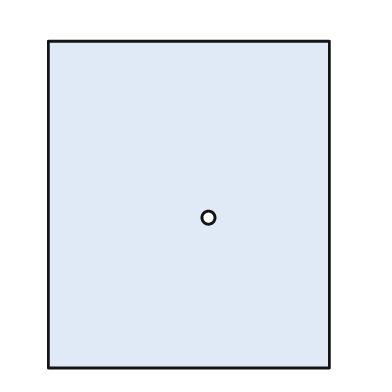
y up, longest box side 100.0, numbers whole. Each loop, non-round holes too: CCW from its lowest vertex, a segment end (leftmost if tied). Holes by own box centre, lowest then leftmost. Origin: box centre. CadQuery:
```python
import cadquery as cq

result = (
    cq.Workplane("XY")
    .moveTo(-43.0, -50.0)
    .lineTo(43.0, -50.0)
    .lineTo(43.0, 50.0)
    .lineTo(-43.0, 50.0)
    .close()
    .moveTo(6.0, -4.0)
    .circle(2.0)
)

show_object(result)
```